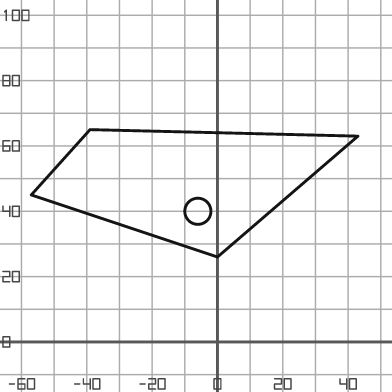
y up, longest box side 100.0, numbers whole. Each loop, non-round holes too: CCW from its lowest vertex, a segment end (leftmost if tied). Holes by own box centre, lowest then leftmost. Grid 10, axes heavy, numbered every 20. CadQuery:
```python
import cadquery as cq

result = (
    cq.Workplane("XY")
    .moveTo(0.0, 26.0)
    .lineTo(43.0, 63.0)
    .lineTo(-39.0, 65.0)
    .lineTo(-57.0, 45.0)
    .close()
    .moveTo(-6.0, 40.0)
    .circle(4.0)
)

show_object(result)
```